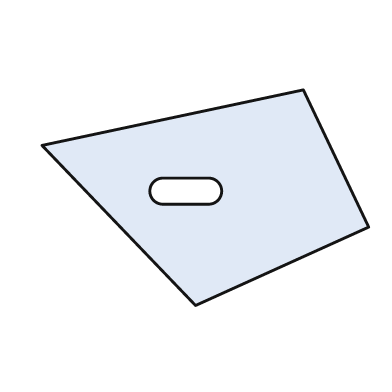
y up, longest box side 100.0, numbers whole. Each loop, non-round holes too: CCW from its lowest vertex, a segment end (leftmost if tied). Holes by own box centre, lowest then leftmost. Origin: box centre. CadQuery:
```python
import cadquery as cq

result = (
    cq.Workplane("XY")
    .moveTo(-3.0, -33.0)
    .lineTo(50.0, -9.0)
    .lineTo(30.0, 33.0)
    .lineTo(-50.0, 16.0)
    .close()
    .moveTo(-13.0, -2.0)
    .lineTo(1.0, -2.0)
    .threePointArc((5.0, 2.0), (1.0, 6.0))
    .lineTo(-13.0, 6.0)
    .threePointArc((-17.0, 2.0), (-13.0, -2.0))
    .close()
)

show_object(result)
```